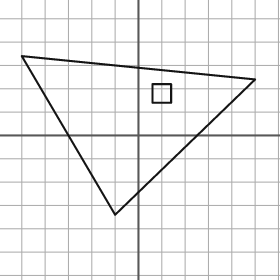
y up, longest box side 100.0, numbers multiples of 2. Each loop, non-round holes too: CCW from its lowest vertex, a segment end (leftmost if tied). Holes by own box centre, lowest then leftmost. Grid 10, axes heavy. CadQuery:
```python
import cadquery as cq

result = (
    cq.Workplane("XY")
    .moveTo(-10.0, -34.0)
    .lineTo(50.0, 24.0)
    .lineTo(-50.0, 34.0)
    .close()
    .moveTo(6.0, 14.0)
    .lineTo(14.0, 14.0)
    .lineTo(14.0, 22.0)
    .lineTo(6.0, 22.0)
    .close()
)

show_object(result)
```